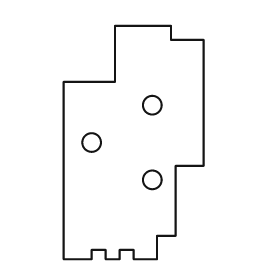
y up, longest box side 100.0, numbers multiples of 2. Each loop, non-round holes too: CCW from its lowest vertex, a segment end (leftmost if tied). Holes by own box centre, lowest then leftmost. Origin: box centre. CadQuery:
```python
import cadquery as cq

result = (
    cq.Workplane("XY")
    .moveTo(-30.0, -50.0)
    .lineTo(-18.0, -50.0)
    .lineTo(-18.0, -46.0)
    .lineTo(-12.0, -46.0)
    .lineTo(-12.0, -50.0)
    .lineTo(-6.0, -50.0)
    .lineTo(-6.0, -46.0)
    .lineTo(0.0, -46.0)
    .lineTo(0.0, -50.0)
    .lineTo(10.0, -50.0)
    .lineTo(10.0, -40.0)
    .lineTo(18.0, -40.0)
    .lineTo(18.0, -10.0)
    .lineTo(30.0, -10.0)
    .lineTo(30.0, 44.0)
    .lineTo(16.0, 44.0)
    .lineTo(16.0, 50.0)
    .lineTo(-8.0, 50.0)
    .lineTo(-8.0, 26.0)
    .lineTo(-30.0, 26.0)
    .close()
    .moveTo(8.0, -16.0)
    .circle(4.0)
    .moveTo(-18.0, 0.0)
    .circle(4.0)
    .moveTo(8.0, 16.0)
    .circle(4.0)
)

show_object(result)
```